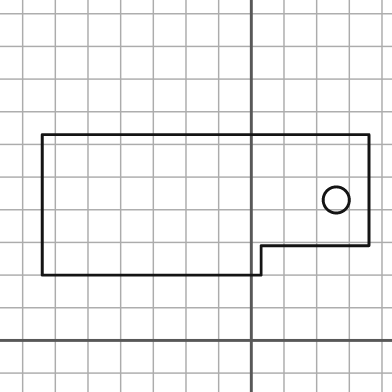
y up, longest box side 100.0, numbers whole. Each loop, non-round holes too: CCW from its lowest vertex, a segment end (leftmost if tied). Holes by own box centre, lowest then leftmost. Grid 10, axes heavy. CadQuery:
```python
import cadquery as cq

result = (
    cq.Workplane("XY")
    .moveTo(-64.0, 20.0)
    .lineTo(3.0, 20.0)
    .lineTo(3.0, 29.0)
    .lineTo(36.0, 29.0)
    .lineTo(36.0, 63.0)
    .lineTo(-64.0, 63.0)
    .close()
    .moveTo(26.0, 43.0)
    .circle(4.0)
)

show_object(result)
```